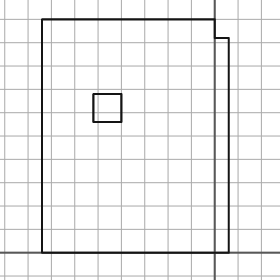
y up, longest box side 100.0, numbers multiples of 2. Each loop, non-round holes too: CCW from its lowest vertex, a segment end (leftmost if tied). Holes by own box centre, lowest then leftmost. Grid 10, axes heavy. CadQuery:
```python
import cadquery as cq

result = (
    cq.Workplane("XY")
    .moveTo(-74.0, 0.0)
    .lineTo(6.0, 0.0)
    .lineTo(6.0, 92.0)
    .lineTo(0.0, 92.0)
    .lineTo(0.0, 100.0)
    .lineTo(-74.0, 100.0)
    .close()
    .moveTo(-52.0, 56.0)
    .lineTo(-40.0, 56.0)
    .lineTo(-40.0, 68.0)
    .lineTo(-52.0, 68.0)
    .close()
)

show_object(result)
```